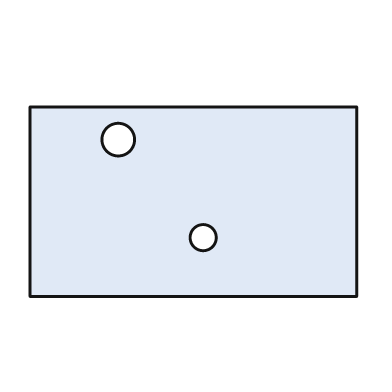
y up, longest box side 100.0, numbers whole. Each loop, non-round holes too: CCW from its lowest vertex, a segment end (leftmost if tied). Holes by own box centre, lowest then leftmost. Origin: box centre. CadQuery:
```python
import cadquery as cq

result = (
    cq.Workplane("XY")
    .moveTo(-50.0, -29.0)
    .lineTo(50.0, -29.0)
    .lineTo(50.0, 29.0)
    .lineTo(-50.0, 29.0)
    .close()
    .moveTo(3.0, -11.0)
    .circle(4.0)
    .moveTo(-23.0, 19.0)
    .circle(5.0)
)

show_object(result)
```